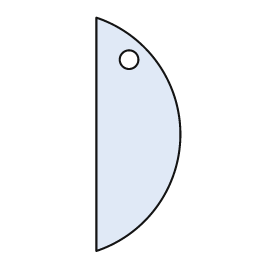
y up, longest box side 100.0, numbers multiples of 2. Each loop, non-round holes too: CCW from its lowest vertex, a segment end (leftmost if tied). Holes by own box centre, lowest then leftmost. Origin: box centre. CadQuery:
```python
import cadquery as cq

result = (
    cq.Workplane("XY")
    .moveTo(-18.0, -50.0)
    .threePointArc((18.0, 0.0), (-18.0, 50.0))
    .close()
    .moveTo(-4.0, 32.0)
    .circle(4.0)
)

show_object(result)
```